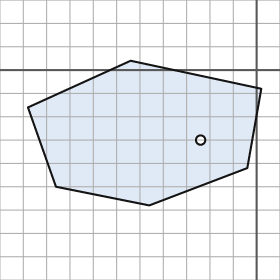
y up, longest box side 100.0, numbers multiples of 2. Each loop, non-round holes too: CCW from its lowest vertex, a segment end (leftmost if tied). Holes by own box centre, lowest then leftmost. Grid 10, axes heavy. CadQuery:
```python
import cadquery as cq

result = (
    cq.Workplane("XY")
    .moveTo(-46.0, -58.0)
    .lineTo(-4.0, -42.0)
    .lineTo(2.0, -8.0)
    .lineTo(-54.0, 4.0)
    .lineTo(-98.0, -16.0)
    .lineTo(-86.0, -50.0)
    .close()
    .moveTo(-24.0, -30.0)
    .circle(2.0)
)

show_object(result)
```